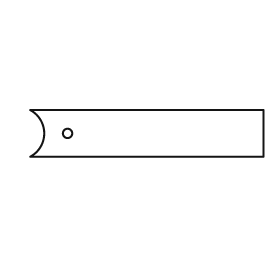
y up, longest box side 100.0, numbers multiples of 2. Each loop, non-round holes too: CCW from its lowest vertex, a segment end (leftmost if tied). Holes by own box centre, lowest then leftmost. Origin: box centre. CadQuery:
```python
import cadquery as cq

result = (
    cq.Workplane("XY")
    .moveTo(-50.0, -10.0)
    .lineTo(50.0, -10.0)
    .lineTo(50.0, 10.0)
    .lineTo(-50.0, 10.0)
    .threePointArc((-44.0, 0.0), (-50.0, -10.0))
    .close()
    .moveTo(-34.0, 0.0)
    .circle(2.0)
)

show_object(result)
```